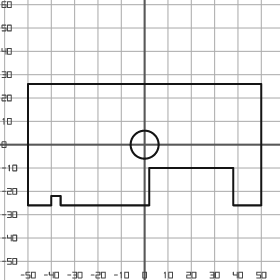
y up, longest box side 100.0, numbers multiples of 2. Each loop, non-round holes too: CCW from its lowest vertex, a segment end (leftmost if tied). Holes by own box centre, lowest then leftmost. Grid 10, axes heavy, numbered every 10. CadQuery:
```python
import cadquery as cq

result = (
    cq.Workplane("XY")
    .moveTo(-50.0, -26.0)
    .lineTo(-40.0, -26.0)
    .lineTo(-40.0, -22.0)
    .lineTo(-36.0, -22.0)
    .lineTo(-36.0, -26.0)
    .lineTo(2.0, -26.0)
    .lineTo(2.0, -10.0)
    .lineTo(38.0, -10.0)
    .lineTo(38.0, -26.0)
    .lineTo(50.0, -26.0)
    .lineTo(50.0, 26.0)
    .lineTo(-50.0, 26.0)
    .close()
    .moveTo(0.0, 0.0)
    .circle(6.0)
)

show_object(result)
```